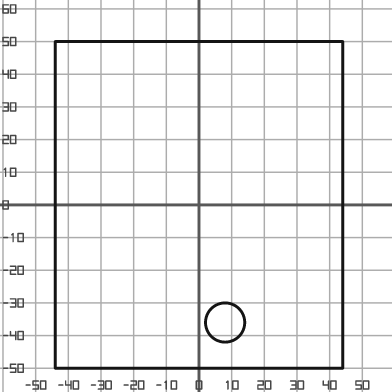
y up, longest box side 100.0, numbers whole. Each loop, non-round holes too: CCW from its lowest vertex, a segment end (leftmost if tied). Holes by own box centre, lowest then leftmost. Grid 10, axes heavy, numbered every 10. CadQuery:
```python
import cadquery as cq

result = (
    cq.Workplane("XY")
    .moveTo(-44.0, -50.0)
    .lineTo(44.0, -50.0)
    .lineTo(44.0, 50.0)
    .lineTo(-44.0, 50.0)
    .close()
    .moveTo(8.0, -36.0)
    .circle(6.0)
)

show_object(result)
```